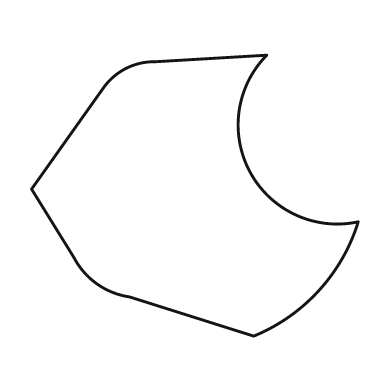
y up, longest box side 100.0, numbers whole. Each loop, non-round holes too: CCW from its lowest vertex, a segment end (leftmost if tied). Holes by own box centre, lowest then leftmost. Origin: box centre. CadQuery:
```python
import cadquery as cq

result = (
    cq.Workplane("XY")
    .moveTo(18.0, -43.0)
    .threePointArc((38.0, -29.0), (50.0, -8.0))
    .threePointArc((17.0, 7.0), (22.0, 43.0))
    .lineTo(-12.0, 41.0)
    .threePointArc((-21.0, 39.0), (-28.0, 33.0))
    .lineTo(-50.0, 2.0)
    .lineTo(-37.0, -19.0)
    .threePointArc((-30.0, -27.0), (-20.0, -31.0))
    .close()
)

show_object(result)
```